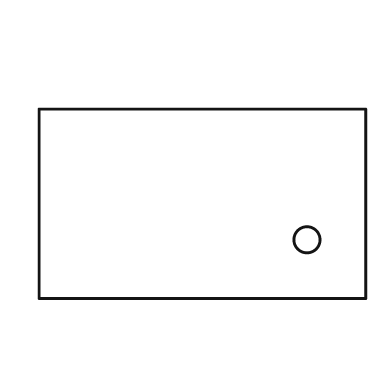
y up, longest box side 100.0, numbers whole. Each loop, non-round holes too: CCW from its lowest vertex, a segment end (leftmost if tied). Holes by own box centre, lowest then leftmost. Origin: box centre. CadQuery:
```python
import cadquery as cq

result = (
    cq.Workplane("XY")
    .moveTo(-50.0, -29.0)
    .lineTo(50.0, -29.0)
    .lineTo(50.0, 29.0)
    .lineTo(-50.0, 29.0)
    .close()
    .moveTo(32.0, -11.0)
    .circle(4.0)
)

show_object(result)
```